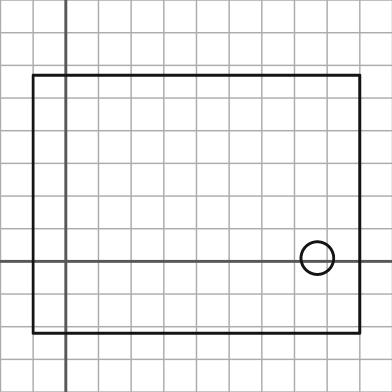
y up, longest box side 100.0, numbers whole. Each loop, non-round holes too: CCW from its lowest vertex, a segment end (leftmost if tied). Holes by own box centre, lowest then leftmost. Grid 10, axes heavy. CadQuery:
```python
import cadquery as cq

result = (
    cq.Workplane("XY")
    .moveTo(-10.0, -22.0)
    .lineTo(90.0, -22.0)
    .lineTo(90.0, 57.0)
    .lineTo(-10.0, 57.0)
    .close()
    .moveTo(77.0, 1.0)
    .circle(5.0)
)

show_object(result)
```